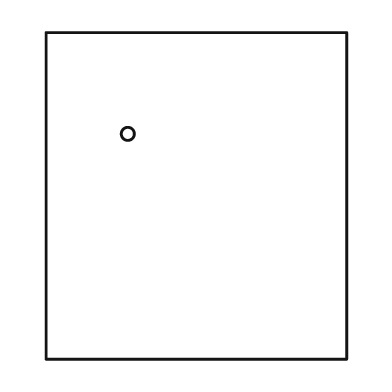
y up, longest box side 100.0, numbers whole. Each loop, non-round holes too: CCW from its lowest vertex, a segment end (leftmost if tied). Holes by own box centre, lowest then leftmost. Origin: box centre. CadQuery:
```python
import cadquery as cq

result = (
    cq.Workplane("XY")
    .moveTo(-46.0, -50.0)
    .lineTo(46.0, -50.0)
    .lineTo(46.0, 50.0)
    .lineTo(-46.0, 50.0)
    .close()
    .moveTo(-21.0, 19.0)
    .circle(2.0)
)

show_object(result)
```